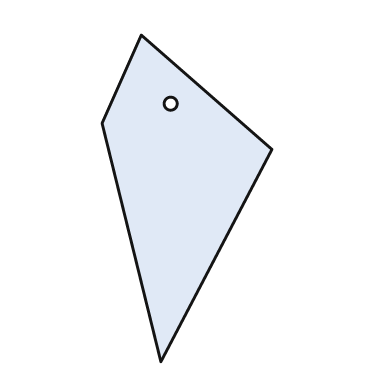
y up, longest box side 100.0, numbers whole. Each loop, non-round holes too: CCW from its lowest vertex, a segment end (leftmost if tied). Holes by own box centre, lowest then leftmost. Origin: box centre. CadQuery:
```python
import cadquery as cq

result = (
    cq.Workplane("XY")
    .moveTo(-8.0, -50.0)
    .lineTo(26.0, 15.0)
    .lineTo(-14.0, 50.0)
    .lineTo(-26.0, 23.0)
    .close()
    .moveTo(-5.0, 29.0)
    .circle(2.0)
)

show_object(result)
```